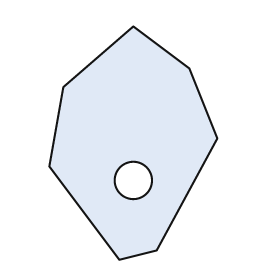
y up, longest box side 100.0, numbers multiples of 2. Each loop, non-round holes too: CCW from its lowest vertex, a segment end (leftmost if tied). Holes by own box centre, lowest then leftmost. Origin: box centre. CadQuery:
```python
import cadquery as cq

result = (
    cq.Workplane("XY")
    .moveTo(-6.0, -50.0)
    .lineTo(10.0, -46.0)
    .lineTo(36.0, 2.0)
    .lineTo(24.0, 32.0)
    .lineTo(0.0, 50.0)
    .lineTo(-30.0, 24.0)
    .lineTo(-36.0, -10.0)
    .close()
    .moveTo(0.0, -16.0)
    .circle(8.0)
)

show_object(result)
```